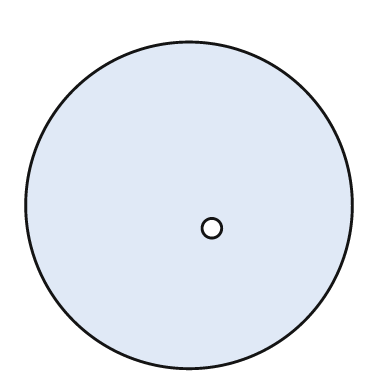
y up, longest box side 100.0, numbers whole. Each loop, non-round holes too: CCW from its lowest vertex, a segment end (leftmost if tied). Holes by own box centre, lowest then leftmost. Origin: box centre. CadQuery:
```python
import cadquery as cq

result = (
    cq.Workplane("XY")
    .moveTo(0.0, 0.0)
    .circle(50.0)
    .moveTo(7.0, -7.0)
    .circle(3.0)
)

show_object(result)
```